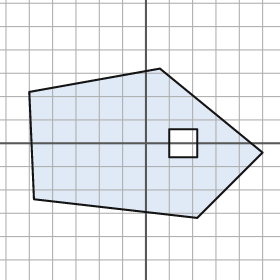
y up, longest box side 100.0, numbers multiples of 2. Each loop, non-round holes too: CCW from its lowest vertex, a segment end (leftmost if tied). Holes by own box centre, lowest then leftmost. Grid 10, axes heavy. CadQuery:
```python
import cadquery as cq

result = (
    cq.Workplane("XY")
    .moveTo(22.0, -32.0)
    .lineTo(50.0, -4.0)
    .lineTo(6.0, 32.0)
    .lineTo(-50.0, 22.0)
    .lineTo(-48.0, -24.0)
    .close()
    .moveTo(10.0, -6.0)
    .lineTo(22.0, -6.0)
    .lineTo(22.0, 6.0)
    .lineTo(10.0, 6.0)
    .close()
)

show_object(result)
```